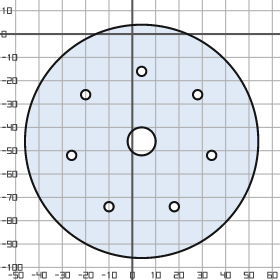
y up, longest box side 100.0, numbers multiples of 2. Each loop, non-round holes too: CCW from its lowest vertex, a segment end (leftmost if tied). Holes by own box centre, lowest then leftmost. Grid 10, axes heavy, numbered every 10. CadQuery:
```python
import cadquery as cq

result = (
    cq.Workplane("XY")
    .moveTo(4.0, -46.0)
    .circle(50.0)
    .moveTo(-10.0, -74.0)
    .circle(2.0)
    .moveTo(18.0, -74.0)
    .circle(2.0)
    .moveTo(-26.0, -52.0)
    .circle(2.0)
    .moveTo(34.0, -52.0)
    .circle(2.0)
    .moveTo(4.0, -46.0)
    .circle(6.0)
    .moveTo(-20.0, -26.0)
    .circle(2.0)
    .moveTo(28.0, -26.0)
    .circle(2.0)
    .moveTo(4.0, -16.0)
    .circle(2.0)
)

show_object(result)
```